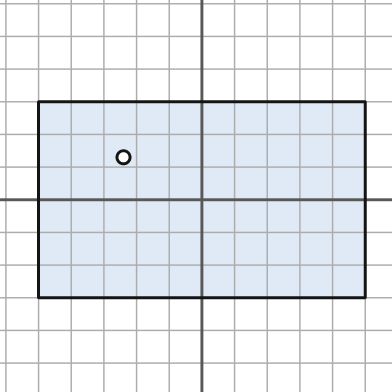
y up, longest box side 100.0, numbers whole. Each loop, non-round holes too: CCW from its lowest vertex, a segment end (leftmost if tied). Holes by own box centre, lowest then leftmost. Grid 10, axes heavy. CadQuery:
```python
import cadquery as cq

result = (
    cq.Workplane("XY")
    .moveTo(-50.0, -30.0)
    .lineTo(50.0, -30.0)
    .lineTo(50.0, 30.0)
    .lineTo(-50.0, 30.0)
    .close()
    .moveTo(-24.0, 13.0)
    .circle(2.0)
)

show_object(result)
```